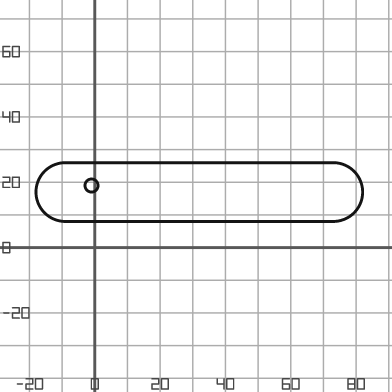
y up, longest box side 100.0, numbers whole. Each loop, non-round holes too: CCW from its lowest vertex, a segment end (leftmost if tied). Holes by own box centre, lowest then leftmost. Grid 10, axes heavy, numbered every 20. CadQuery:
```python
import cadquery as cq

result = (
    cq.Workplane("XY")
    .moveTo(-9.0, 8.0)
    .lineTo(73.0, 8.0)
    .threePointArc((82.0, 17.0), (73.0, 26.0))
    .lineTo(-9.0, 26.0)
    .threePointArc((-18.0, 17.0), (-9.0, 8.0))
    .close()
    .moveTo(-1.0, 19.0)
    .circle(2.0)
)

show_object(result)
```